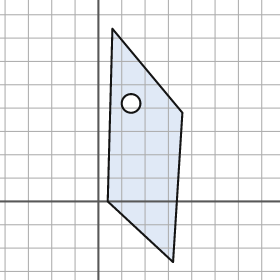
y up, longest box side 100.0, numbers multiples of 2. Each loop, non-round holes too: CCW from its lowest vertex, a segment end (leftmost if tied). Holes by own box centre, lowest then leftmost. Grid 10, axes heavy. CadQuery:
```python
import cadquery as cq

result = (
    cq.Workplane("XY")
    .moveTo(32.0, -26.0)
    .lineTo(36.0, 38.0)
    .lineTo(6.0, 74.0)
    .lineTo(4.0, 0.0)
    .close()
    .moveTo(14.0, 42.0)
    .circle(4.0)
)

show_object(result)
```